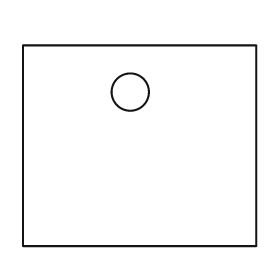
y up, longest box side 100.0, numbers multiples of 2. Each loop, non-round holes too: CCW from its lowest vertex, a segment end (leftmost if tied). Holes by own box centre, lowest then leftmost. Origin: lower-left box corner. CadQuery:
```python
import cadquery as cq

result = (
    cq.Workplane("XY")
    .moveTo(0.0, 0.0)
    .lineTo(100.0, 0.0)
    .lineTo(100.0, 86.0)
    .lineTo(0.0, 86.0)
    .close()
    .moveTo(46.0, 66.0)
    .circle(8.0)
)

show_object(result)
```